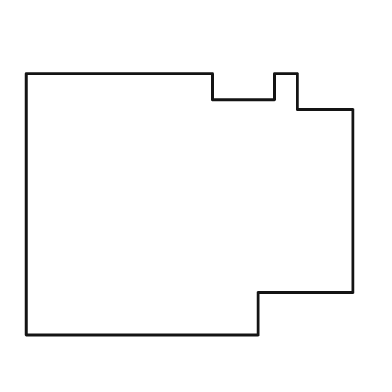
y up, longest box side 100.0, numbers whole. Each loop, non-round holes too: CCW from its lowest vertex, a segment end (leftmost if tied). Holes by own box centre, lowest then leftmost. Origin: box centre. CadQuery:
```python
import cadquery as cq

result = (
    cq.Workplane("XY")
    .moveTo(-50.0, -40.0)
    .lineTo(21.0, -40.0)
    .lineTo(21.0, -27.0)
    .lineTo(50.0, -27.0)
    .lineTo(50.0, 29.0)
    .lineTo(33.0, 29.0)
    .lineTo(33.0, 40.0)
    .lineTo(26.0, 40.0)
    .lineTo(26.0, 32.0)
    .lineTo(7.0, 32.0)
    .lineTo(7.0, 40.0)
    .lineTo(-50.0, 40.0)
    .close()
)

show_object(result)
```